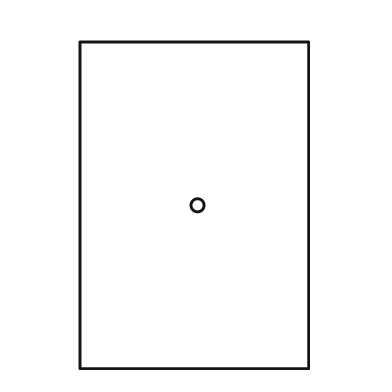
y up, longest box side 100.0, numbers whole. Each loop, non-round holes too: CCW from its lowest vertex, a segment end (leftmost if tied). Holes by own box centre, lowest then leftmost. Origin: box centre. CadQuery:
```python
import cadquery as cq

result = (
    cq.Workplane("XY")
    .moveTo(-35.0, -50.0)
    .lineTo(35.0, -50.0)
    .lineTo(35.0, 50.0)
    .lineTo(-35.0, 50.0)
    .close()
    .moveTo(1.0, 0.0)
    .circle(2.0)
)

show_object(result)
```